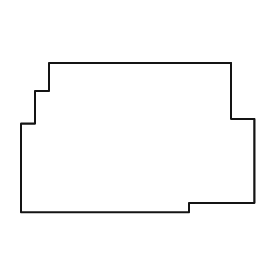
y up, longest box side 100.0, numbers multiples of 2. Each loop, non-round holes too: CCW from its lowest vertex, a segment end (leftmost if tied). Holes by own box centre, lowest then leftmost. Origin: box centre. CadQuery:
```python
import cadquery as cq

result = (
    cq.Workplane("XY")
    .moveTo(-50.0, -32.0)
    .lineTo(22.0, -32.0)
    .lineTo(22.0, -28.0)
    .lineTo(50.0, -28.0)
    .lineTo(50.0, 8.0)
    .lineTo(40.0, 8.0)
    .lineTo(40.0, 32.0)
    .lineTo(-38.0, 32.0)
    .lineTo(-38.0, 20.0)
    .lineTo(-44.0, 20.0)
    .lineTo(-44.0, 6.0)
    .lineTo(-50.0, 6.0)
    .close()
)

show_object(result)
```